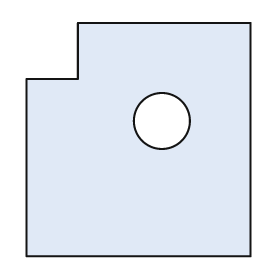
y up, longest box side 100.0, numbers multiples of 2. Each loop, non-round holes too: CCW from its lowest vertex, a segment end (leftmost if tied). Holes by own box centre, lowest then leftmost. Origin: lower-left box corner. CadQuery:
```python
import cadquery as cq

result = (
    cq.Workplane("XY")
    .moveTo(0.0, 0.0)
    .lineTo(96.0, 0.0)
    .lineTo(96.0, 100.0)
    .lineTo(22.0, 100.0)
    .lineTo(22.0, 76.0)
    .lineTo(0.0, 76.0)
    .close()
    .moveTo(58.0, 58.0)
    .circle(12.0)
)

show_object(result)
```